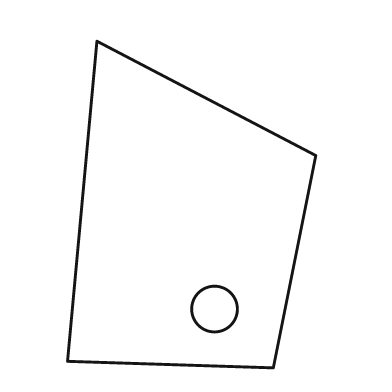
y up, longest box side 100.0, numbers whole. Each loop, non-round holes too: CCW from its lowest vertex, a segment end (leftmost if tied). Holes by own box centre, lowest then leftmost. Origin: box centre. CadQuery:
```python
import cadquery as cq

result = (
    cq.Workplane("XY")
    .moveTo(25.0, -50.0)
    .lineTo(38.0, 15.0)
    .lineTo(-29.0, 50.0)
    .lineTo(-38.0, -48.0)
    .close()
    .moveTo(7.0, -32.0)
    .circle(7.0)
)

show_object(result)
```